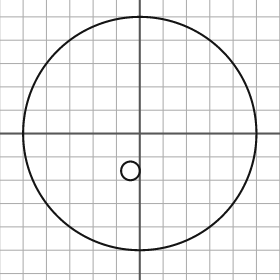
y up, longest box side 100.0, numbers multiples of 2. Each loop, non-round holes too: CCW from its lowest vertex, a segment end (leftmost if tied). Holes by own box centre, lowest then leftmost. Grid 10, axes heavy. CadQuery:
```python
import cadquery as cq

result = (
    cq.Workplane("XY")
    .moveTo(0.0, 0.0)
    .circle(50.0)
    .moveTo(-4.0, -16.0)
    .circle(4.0)
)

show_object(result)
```